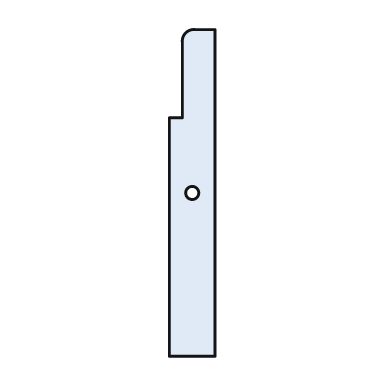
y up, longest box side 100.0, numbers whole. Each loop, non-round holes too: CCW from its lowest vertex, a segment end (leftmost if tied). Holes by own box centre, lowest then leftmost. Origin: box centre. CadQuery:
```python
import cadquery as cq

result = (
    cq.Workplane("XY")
    .moveTo(-7.0, -50.0)
    .lineTo(7.0, -50.0)
    .lineTo(7.0, 50.0)
    .lineTo(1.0, 50.0)
    .threePointArc((-2.0, 49.0), (-3.0, 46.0))
    .lineTo(-3.0, 23.0)
    .lineTo(-7.0, 23.0)
    .close()
    .moveTo(0.0, 0.0)
    .circle(2.0)
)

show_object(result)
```